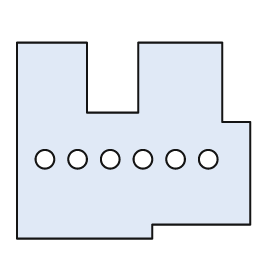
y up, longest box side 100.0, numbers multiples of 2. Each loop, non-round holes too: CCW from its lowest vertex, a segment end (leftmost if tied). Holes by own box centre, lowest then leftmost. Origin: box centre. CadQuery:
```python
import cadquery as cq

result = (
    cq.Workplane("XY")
    .moveTo(-50.0, -42.0)
    .lineTo(8.0, -42.0)
    .lineTo(8.0, -36.0)
    .lineTo(50.0, -36.0)
    .lineTo(50.0, 8.0)
    .lineTo(38.0, 8.0)
    .lineTo(38.0, 42.0)
    .lineTo(2.0, 42.0)
    .lineTo(2.0, 12.0)
    .lineTo(-20.0, 12.0)
    .lineTo(-20.0, 42.0)
    .lineTo(-50.0, 42.0)
    .close()
    .moveTo(-38.0, -8.0)
    .circle(4.0)
    .moveTo(-24.0, -8.0)
    .circle(4.0)
    .moveTo(-10.0, -8.0)
    .circle(4.0)
    .moveTo(4.0, -8.0)
    .circle(4.0)
    .moveTo(18.0, -8.0)
    .circle(4.0)
    .moveTo(32.0, -8.0)
    .circle(4.0)
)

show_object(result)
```